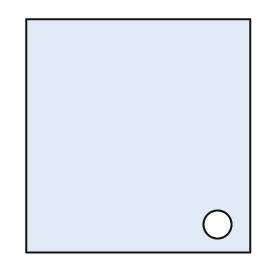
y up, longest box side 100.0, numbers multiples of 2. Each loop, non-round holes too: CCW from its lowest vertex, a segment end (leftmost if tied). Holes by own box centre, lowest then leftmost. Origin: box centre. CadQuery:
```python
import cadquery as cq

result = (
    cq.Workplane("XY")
    .moveTo(-48.0, -50.0)
    .lineTo(48.0, -50.0)
    .lineTo(48.0, 50.0)
    .lineTo(-48.0, 50.0)
    .close()
    .moveTo(34.0, -38.0)
    .circle(6.0)
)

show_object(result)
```